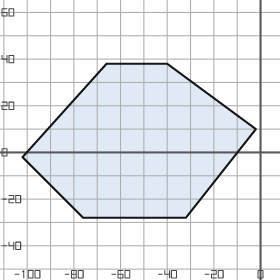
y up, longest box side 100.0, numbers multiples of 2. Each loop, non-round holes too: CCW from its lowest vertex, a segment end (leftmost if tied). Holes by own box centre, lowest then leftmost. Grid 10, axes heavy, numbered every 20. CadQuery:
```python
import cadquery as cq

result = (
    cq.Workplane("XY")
    .moveTo(-76.0, -28.0)
    .lineTo(-32.0, -28.0)
    .lineTo(-2.0, 10.0)
    .lineTo(-40.0, 38.0)
    .lineTo(-66.0, 38.0)
    .lineTo(-102.0, -2.0)
    .close()
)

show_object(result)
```